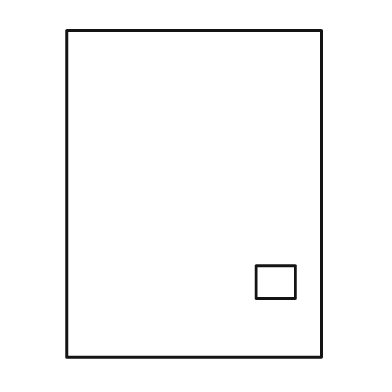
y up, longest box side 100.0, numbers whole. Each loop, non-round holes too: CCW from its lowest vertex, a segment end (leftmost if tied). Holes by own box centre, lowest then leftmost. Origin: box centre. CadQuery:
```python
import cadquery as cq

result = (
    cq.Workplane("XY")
    .moveTo(-39.0, -50.0)
    .lineTo(39.0, -50.0)
    .lineTo(39.0, 50.0)
    .lineTo(-39.0, 50.0)
    .close()
    .moveTo(19.0, -32.0)
    .lineTo(31.0, -32.0)
    .lineTo(31.0, -22.0)
    .lineTo(19.0, -22.0)
    .close()
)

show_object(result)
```